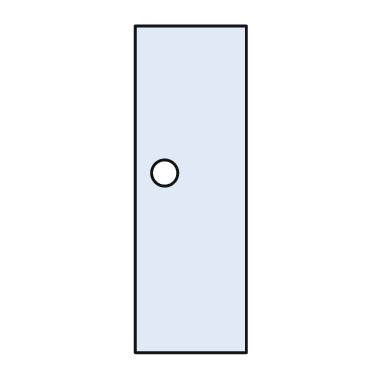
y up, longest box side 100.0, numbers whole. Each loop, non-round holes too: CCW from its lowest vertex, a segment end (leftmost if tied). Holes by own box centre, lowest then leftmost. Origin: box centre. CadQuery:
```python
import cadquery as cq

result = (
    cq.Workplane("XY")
    .moveTo(-17.0, -50.0)
    .lineTo(17.0, -50.0)
    .lineTo(17.0, 50.0)
    .lineTo(-17.0, 50.0)
    .close()
    .moveTo(-8.0, 5.0)
    .circle(4.0)
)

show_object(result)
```